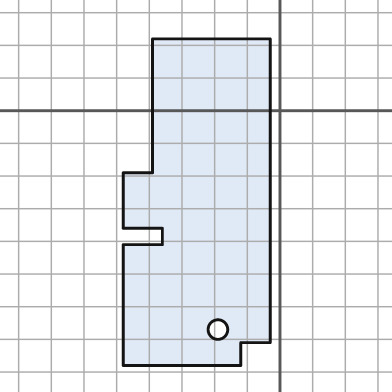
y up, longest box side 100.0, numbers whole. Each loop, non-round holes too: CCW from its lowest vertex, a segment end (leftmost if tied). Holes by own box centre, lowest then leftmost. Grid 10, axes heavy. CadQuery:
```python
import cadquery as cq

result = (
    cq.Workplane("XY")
    .moveTo(-48.0, -78.0)
    .lineTo(-12.0, -78.0)
    .lineTo(-12.0, -71.0)
    .lineTo(-3.0, -71.0)
    .lineTo(-3.0, 22.0)
    .lineTo(-39.0, 22.0)
    .lineTo(-39.0, -19.0)
    .lineTo(-48.0, -19.0)
    .lineTo(-48.0, -36.0)
    .lineTo(-36.0, -36.0)
    .lineTo(-36.0, -41.0)
    .lineTo(-48.0, -41.0)
    .close()
    .moveTo(-19.0, -67.0)
    .circle(3.0)
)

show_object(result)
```